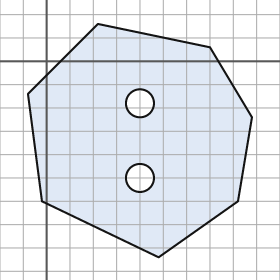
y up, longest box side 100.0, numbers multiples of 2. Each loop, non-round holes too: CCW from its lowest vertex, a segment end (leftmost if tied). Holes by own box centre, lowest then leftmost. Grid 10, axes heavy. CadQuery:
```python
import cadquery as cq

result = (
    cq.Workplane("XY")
    .moveTo(48.0, -84.0)
    .lineTo(82.0, -60.0)
    .lineTo(88.0, -24.0)
    .lineTo(70.0, 6.0)
    .lineTo(22.0, 16.0)
    .lineTo(-8.0, -14.0)
    .lineTo(-2.0, -60.0)
    .close()
    .moveTo(40.0, -50.0)
    .circle(6.0)
    .moveTo(40.0, -18.0)
    .circle(6.0)
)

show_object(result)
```